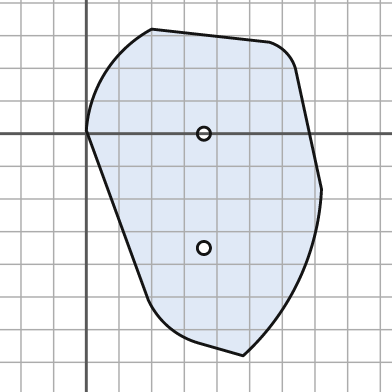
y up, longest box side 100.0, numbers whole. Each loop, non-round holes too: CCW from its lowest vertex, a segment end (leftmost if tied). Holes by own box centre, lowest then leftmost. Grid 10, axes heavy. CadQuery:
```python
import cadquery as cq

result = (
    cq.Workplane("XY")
    .moveTo(48.0, -68.0)
    .threePointArc((65.0, -45.0), (72.0, -17.0))
    .lineTo(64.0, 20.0)
    .threePointArc((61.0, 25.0), (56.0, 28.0))
    .lineTo(20.0, 32.0)
    .threePointArc((6.0, 19.0), (0.0, 1.0))
    .lineTo(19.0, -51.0)
    .threePointArc((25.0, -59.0), (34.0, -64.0))
    .close()
    .moveTo(36.0, -35.0)
    .circle(2.0)
    .moveTo(36.0, 0.0)
    .circle(2.0)
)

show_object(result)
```